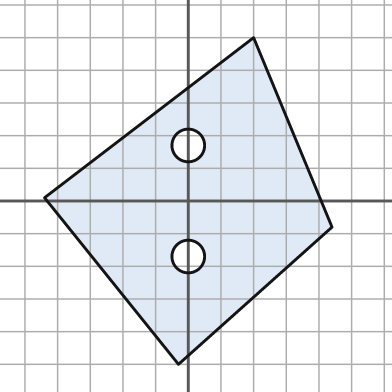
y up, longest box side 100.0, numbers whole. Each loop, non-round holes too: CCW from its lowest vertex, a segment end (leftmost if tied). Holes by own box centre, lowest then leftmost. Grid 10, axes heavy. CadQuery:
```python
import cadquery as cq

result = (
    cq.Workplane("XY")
    .moveTo(-3.0, -50.0)
    .lineTo(44.0, -8.0)
    .lineTo(20.0, 50.0)
    .lineTo(-44.0, 1.0)
    .close()
    .moveTo(0.0, -17.0)
    .circle(5.0)
    .moveTo(0.0, 17.0)
    .circle(5.0)
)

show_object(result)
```